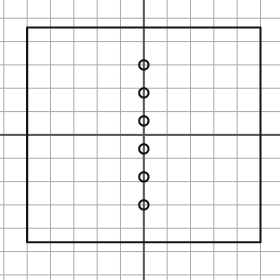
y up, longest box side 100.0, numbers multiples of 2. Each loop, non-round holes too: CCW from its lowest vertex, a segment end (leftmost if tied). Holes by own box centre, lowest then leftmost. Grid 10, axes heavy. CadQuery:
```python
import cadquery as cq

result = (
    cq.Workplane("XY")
    .moveTo(-50.0, -46.0)
    .lineTo(50.0, -46.0)
    .lineTo(50.0, 46.0)
    .lineTo(-50.0, 46.0)
    .close()
    .moveTo(0.0, -30.0)
    .circle(2.0)
    .moveTo(0.0, -18.0)
    .circle(2.0)
    .moveTo(0.0, -6.0)
    .circle(2.0)
    .moveTo(0.0, 6.0)
    .circle(2.0)
    .moveTo(0.0, 18.0)
    .circle(2.0)
    .moveTo(0.0, 30.0)
    .circle(2.0)
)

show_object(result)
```